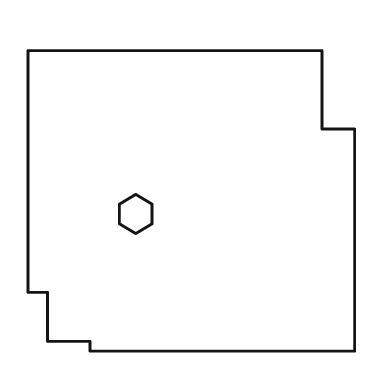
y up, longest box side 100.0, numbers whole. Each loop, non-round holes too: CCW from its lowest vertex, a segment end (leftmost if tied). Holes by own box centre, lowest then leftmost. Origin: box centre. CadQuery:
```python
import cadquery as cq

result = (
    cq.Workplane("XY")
    .moveTo(-31.0, -46.0)
    .lineTo(50.0, -46.0)
    .lineTo(50.0, 22.0)
    .lineTo(40.0, 22.0)
    .lineTo(40.0, 46.0)
    .lineTo(-50.0, 46.0)
    .lineTo(-50.0, -28.0)
    .lineTo(-44.0, -28.0)
    .lineTo(-44.0, -43.0)
    .lineTo(-31.0, -43.0)
    .close()
    .moveTo(-17.0, -10.0)
    .lineTo(-12.0, -7.0)
    .lineTo(-12.0, -1.0)
    .lineTo(-17.0, 2.0)
    .lineTo(-22.0, -1.0)
    .lineTo(-22.0, -7.0)
    .close()
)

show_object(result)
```